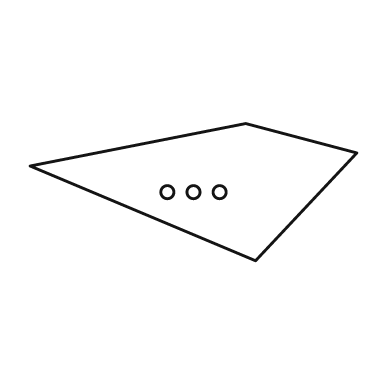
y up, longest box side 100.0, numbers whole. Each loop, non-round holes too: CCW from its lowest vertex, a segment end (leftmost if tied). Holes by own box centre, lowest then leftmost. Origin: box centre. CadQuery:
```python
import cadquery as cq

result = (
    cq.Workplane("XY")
    .moveTo(19.0, -21.0)
    .lineTo(50.0, 12.0)
    .lineTo(16.0, 21.0)
    .lineTo(-50.0, 8.0)
    .close()
    .moveTo(-8.0, 0.0)
    .circle(2.0)
    .moveTo(0.0, 0.0)
    .circle(2.0)
    .moveTo(8.0, 0.0)
    .circle(2.0)
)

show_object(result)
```